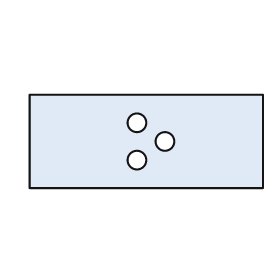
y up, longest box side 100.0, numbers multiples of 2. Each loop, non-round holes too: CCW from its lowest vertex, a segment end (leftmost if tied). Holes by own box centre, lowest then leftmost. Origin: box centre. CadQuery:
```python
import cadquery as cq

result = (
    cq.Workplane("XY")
    .moveTo(-50.0, -20.0)
    .lineTo(50.0, -20.0)
    .lineTo(50.0, 20.0)
    .lineTo(-50.0, 20.0)
    .close()
    .moveTo(-4.0, -8.0)
    .circle(4.0)
    .moveTo(8.0, 0.0)
    .circle(4.0)
    .moveTo(-4.0, 8.0)
    .circle(4.0)
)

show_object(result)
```